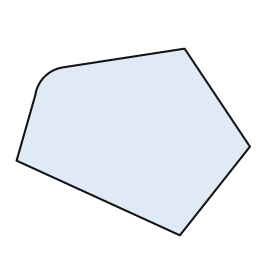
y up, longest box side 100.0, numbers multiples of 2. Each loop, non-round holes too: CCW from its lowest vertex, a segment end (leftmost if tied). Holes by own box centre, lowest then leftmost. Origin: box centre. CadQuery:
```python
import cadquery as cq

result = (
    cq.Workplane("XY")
    .moveTo(20.0, -40.0)
    .lineTo(50.0, -2.0)
    .lineTo(22.0, 40.0)
    .lineTo(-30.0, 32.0)
    .threePointArc((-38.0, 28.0), (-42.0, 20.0))
    .lineTo(-50.0, -8.0)
    .close()
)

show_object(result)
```